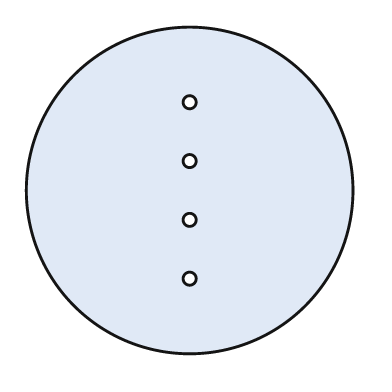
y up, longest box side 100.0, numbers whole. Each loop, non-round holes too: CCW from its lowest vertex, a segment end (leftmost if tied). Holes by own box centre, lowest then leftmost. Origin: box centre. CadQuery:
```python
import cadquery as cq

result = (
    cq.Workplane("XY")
    .moveTo(0.0, 0.0)
    .circle(50.0)
    .moveTo(0.0, -27.0)
    .circle(2.0)
    .moveTo(0.0, -9.0)
    .circle(2.0)
    .moveTo(0.0, 9.0)
    .circle(2.0)
    .moveTo(0.0, 27.0)
    .circle(2.0)
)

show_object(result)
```